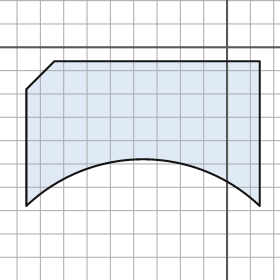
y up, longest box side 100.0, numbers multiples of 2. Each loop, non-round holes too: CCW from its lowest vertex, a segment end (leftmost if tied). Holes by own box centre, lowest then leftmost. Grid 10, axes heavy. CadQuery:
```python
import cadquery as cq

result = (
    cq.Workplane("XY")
    .moveTo(-86.0, -68.0)
    .threePointArc((-36.0, -48.0), (14.0, -68.0))
    .lineTo(14.0, -6.0)
    .lineTo(-74.0, -6.0)
    .lineTo(-86.0, -18.0)
    .close()
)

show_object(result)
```